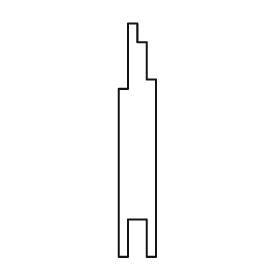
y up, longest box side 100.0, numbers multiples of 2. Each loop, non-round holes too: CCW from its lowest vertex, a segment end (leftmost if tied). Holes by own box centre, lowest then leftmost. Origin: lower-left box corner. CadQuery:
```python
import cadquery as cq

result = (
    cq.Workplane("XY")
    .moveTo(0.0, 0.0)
    .lineTo(4.0, 0.0)
    .lineTo(4.0, 16.0)
    .lineTo(12.0, 16.0)
    .lineTo(12.0, 0.0)
    .lineTo(16.0, 0.0)
    .lineTo(16.0, 76.0)
    .lineTo(12.0, 76.0)
    .lineTo(12.0, 92.0)
    .lineTo(8.0, 92.0)
    .lineTo(8.0, 100.0)
    .lineTo(4.0, 100.0)
    .lineTo(4.0, 72.0)
    .lineTo(0.0, 72.0)
    .close()
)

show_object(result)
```